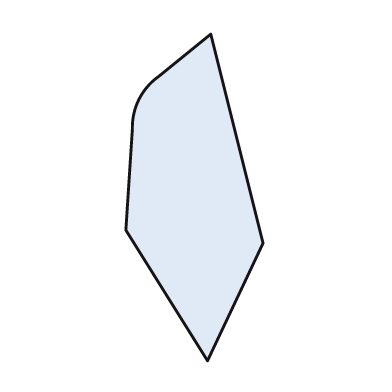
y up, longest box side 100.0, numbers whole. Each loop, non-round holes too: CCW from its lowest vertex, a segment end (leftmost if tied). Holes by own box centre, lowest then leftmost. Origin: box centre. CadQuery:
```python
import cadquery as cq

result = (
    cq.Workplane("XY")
    .moveTo(4.0, -50.0)
    .lineTo(21.0, -14.0)
    .lineTo(5.0, 50.0)
    .lineTo(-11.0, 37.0)
    .threePointArc((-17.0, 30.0), (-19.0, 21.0))
    .lineTo(-21.0, -10.0)
    .close()
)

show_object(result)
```